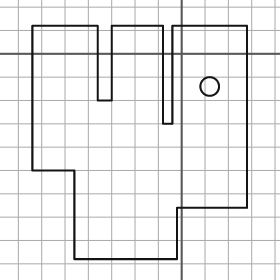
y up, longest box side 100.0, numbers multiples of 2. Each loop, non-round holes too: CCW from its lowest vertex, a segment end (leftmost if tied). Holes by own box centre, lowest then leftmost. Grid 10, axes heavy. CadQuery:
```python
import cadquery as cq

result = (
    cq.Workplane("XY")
    .moveTo(-46.0, -88.0)
    .lineTo(-2.0, -88.0)
    .lineTo(-2.0, -66.0)
    .lineTo(28.0, -66.0)
    .lineTo(28.0, 12.0)
    .lineTo(-4.0, 12.0)
    .lineTo(-4.0, -30.0)
    .lineTo(-8.0, -30.0)
    .lineTo(-8.0, 12.0)
    .lineTo(-30.0, 12.0)
    .lineTo(-30.0, -20.0)
    .lineTo(-36.0, -20.0)
    .lineTo(-36.0, 12.0)
    .lineTo(-64.0, 12.0)
    .lineTo(-64.0, -50.0)
    .lineTo(-46.0, -50.0)
    .close()
    .moveTo(12.0, -14.0)
    .circle(4.0)
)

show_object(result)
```